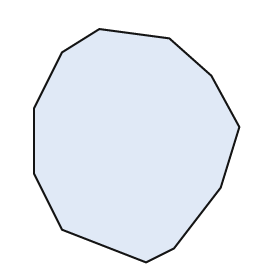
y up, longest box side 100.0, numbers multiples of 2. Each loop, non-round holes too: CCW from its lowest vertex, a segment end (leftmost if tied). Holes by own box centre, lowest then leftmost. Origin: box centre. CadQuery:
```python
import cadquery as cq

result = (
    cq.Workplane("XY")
    .moveTo(4.0, -50.0)
    .lineTo(16.0, -44.0)
    .lineTo(36.0, -18.0)
    .lineTo(44.0, 8.0)
    .lineTo(32.0, 30.0)
    .lineTo(14.0, 46.0)
    .lineTo(-16.0, 50.0)
    .lineTo(-32.0, 40.0)
    .lineTo(-44.0, 16.0)
    .lineTo(-44.0, -12.0)
    .lineTo(-32.0, -36.0)
    .close()
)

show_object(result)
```